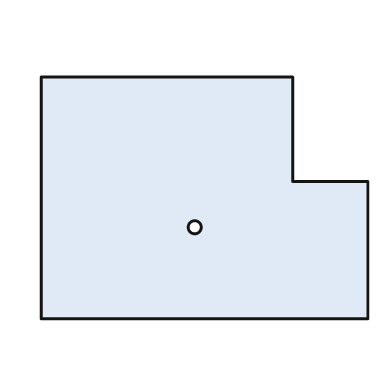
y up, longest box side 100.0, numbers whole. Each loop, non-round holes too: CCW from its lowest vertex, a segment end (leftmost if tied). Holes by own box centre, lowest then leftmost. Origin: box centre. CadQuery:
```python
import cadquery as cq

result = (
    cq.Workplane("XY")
    .moveTo(-50.0, -37.0)
    .lineTo(50.0, -37.0)
    .lineTo(50.0, 5.0)
    .lineTo(27.0, 5.0)
    .lineTo(27.0, 37.0)
    .lineTo(-50.0, 37.0)
    .close()
    .moveTo(-3.0, -9.0)
    .circle(2.0)
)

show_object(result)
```